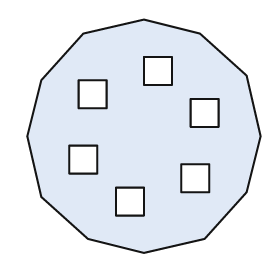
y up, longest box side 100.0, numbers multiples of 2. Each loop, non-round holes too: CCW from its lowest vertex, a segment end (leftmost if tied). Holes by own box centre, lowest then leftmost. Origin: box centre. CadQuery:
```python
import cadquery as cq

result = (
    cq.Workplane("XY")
    .moveTo(0.0, -50.0)
    .lineTo(26.0, -44.0)
    .lineTo(44.0, -24.0)
    .lineTo(50.0, 0.0)
    .lineTo(44.0, 26.0)
    .lineTo(24.0, 44.0)
    .lineTo(0.0, 50.0)
    .lineTo(-26.0, 44.0)
    .lineTo(-44.0, 24.0)
    .lineTo(-50.0, 0.0)
    .lineTo(-44.0, -26.0)
    .lineTo(-24.0, -44.0)
    .close()
    .moveTo(-12.0, -34.0)
    .lineTo(0.0, -34.0)
    .lineTo(0.0, -22.0)
    .lineTo(-12.0, -22.0)
    .close()
    .moveTo(16.0, -24.0)
    .lineTo(28.0, -24.0)
    .lineTo(28.0, -12.0)
    .lineTo(16.0, -12.0)
    .close()
    .moveTo(-32.0, -16.0)
    .lineTo(-20.0, -16.0)
    .lineTo(-20.0, -4.0)
    .lineTo(-32.0, -4.0)
    .close()
    .moveTo(20.0, 4.0)
    .lineTo(32.0, 4.0)
    .lineTo(32.0, 16.0)
    .lineTo(20.0, 16.0)
    .close()
    .moveTo(-28.0, 12.0)
    .lineTo(-16.0, 12.0)
    .lineTo(-16.0, 24.0)
    .lineTo(-28.0, 24.0)
    .close()
    .moveTo(0.0, 22.0)
    .lineTo(12.0, 22.0)
    .lineTo(12.0, 34.0)
    .lineTo(0.0, 34.0)
    .close()
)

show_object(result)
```